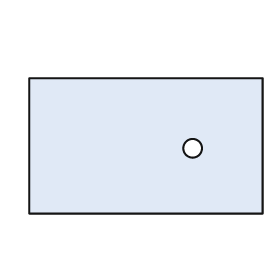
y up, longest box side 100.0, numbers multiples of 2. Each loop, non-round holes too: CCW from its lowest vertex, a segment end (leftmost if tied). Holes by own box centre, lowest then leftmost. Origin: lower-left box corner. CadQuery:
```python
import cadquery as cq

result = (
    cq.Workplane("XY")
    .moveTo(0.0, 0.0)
    .lineTo(100.0, 0.0)
    .lineTo(100.0, 58.0)
    .lineTo(0.0, 58.0)
    .close()
    .moveTo(70.0, 28.0)
    .circle(4.0)
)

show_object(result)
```